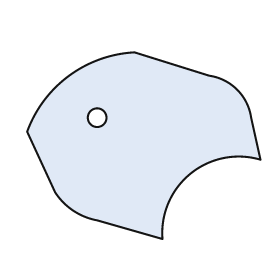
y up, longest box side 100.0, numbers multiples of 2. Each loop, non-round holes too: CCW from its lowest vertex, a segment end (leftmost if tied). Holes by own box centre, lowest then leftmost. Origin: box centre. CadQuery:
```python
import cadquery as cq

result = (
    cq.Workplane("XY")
    .moveTo(8.0, -40.0)
    .threePointArc((20.0, -12.0), (50.0, -6.0))
    .lineTo(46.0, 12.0)
    .threePointArc((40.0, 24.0), (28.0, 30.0))
    .lineTo(-4.0, 40.0)
    .threePointArc((-32.0, 30.0), (-50.0, 6.0))
    .lineTo(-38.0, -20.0)
    .threePointArc((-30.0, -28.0), (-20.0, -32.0))
    .close()
    .moveTo(-20.0, 12.0)
    .circle(4.0)
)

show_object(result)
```